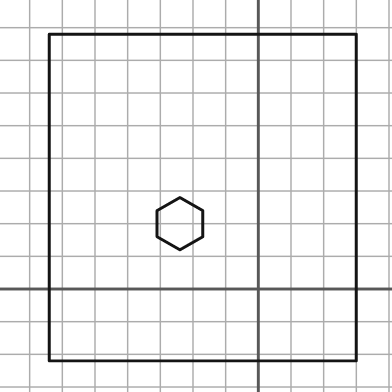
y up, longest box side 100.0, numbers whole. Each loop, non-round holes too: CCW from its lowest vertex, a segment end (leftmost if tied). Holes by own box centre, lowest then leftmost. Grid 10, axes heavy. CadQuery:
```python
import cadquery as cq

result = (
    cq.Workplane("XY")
    .moveTo(-64.0, -22.0)
    .lineTo(30.0, -22.0)
    .lineTo(30.0, 78.0)
    .lineTo(-64.0, 78.0)
    .close()
    .moveTo(-24.0, 12.0)
    .lineTo(-17.0, 16.0)
    .lineTo(-17.0, 24.0)
    .lineTo(-24.0, 28.0)
    .lineTo(-31.0, 24.0)
    .lineTo(-31.0, 16.0)
    .close()
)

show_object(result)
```